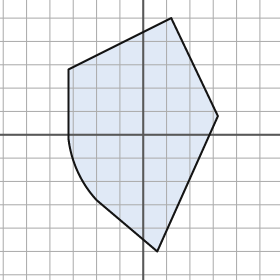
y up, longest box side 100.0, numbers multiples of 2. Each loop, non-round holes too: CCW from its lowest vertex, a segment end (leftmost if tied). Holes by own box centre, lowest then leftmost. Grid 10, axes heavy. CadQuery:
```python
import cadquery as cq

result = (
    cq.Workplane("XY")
    .moveTo(6.0, -50.0)
    .lineTo(32.0, 8.0)
    .lineTo(12.0, 50.0)
    .lineTo(-32.0, 28.0)
    .lineTo(-32.0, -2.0)
    .threePointArc((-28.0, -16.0), (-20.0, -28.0))
    .close()
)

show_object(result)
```